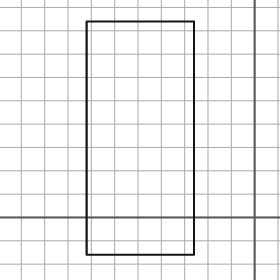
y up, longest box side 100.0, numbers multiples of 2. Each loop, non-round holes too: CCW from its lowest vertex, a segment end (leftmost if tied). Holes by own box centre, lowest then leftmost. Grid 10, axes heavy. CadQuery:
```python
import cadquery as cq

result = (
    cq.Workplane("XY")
    .moveTo(-72.0, -16.0)
    .lineTo(-26.0, -16.0)
    .lineTo(-26.0, 84.0)
    .lineTo(-72.0, 84.0)
    .close()
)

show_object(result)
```